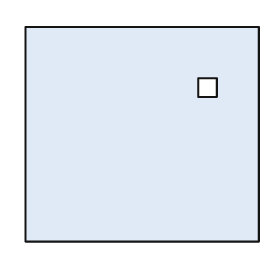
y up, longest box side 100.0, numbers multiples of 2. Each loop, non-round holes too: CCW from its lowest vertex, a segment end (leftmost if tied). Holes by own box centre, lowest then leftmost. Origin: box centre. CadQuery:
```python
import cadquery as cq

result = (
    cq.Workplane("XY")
    .moveTo(-50.0, -46.0)
    .lineTo(50.0, -46.0)
    .lineTo(50.0, 46.0)
    .lineTo(-50.0, 46.0)
    .close()
    .moveTo(24.0, 16.0)
    .lineTo(32.0, 16.0)
    .lineTo(32.0, 24.0)
    .lineTo(24.0, 24.0)
    .close()
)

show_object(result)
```